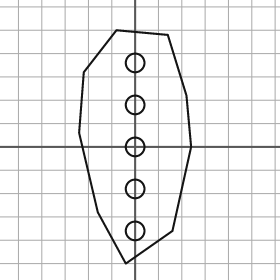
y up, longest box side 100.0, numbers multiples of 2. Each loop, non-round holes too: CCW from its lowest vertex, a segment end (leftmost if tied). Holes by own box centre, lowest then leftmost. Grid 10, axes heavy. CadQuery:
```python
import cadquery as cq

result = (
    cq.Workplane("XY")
    .moveTo(-4.0, -50.0)
    .lineTo(16.0, -36.0)
    .lineTo(24.0, 0.0)
    .lineTo(22.0, 22.0)
    .lineTo(14.0, 48.0)
    .lineTo(-8.0, 50.0)
    .lineTo(-22.0, 32.0)
    .lineTo(-24.0, 6.0)
    .lineTo(-16.0, -28.0)
    .close()
    .moveTo(0.0, -36.0)
    .circle(4.0)
    .moveTo(0.0, -18.0)
    .circle(4.0)
    .moveTo(0.0, 0.0)
    .circle(4.0)
    .moveTo(0.0, 18.0)
    .circle(4.0)
    .moveTo(0.0, 36.0)
    .circle(4.0)
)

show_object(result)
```